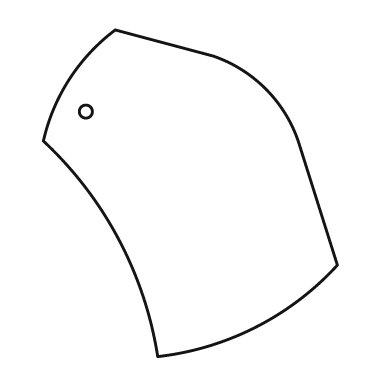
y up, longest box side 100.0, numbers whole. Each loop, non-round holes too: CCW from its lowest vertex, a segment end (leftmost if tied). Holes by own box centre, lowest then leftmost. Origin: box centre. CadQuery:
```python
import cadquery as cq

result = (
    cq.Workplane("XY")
    .moveTo(-10.0, -50.0)
    .threePointArc((20.0, -41.0), (45.0, -22.0))
    .lineTo(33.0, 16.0)
    .threePointArc((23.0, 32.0), (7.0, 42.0))
    .lineTo(-23.0, 50.0)
    .threePointArc((-37.0, 35.0), (-45.0, 16.0))
    .threePointArc((-22.0, -14.0), (-10.0, -50.0))
    .close()
    .moveTo(-32.0, 25.0)
    .circle(2.0)
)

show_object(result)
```